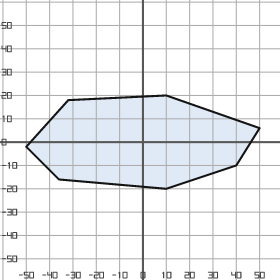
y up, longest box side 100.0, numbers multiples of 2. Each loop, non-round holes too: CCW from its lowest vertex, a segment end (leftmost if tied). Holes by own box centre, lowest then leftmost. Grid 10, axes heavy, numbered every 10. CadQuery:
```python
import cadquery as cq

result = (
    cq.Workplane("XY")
    .moveTo(10.0, -20.0)
    .lineTo(40.0, -10.0)
    .lineTo(50.0, 6.0)
    .lineTo(10.0, 20.0)
    .lineTo(-32.0, 18.0)
    .lineTo(-50.0, -2.0)
    .lineTo(-36.0, -16.0)
    .close()
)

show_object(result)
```